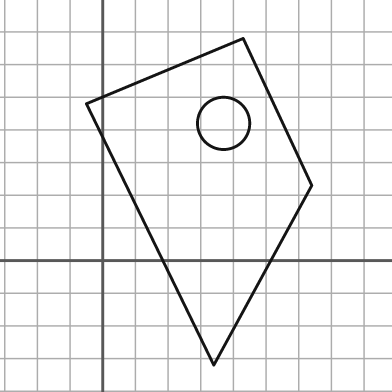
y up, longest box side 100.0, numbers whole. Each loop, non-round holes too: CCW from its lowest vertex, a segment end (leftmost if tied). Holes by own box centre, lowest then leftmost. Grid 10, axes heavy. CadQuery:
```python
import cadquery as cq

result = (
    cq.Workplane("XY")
    .moveTo(34.0, -32.0)
    .lineTo(64.0, 23.0)
    .lineTo(43.0, 68.0)
    .lineTo(-5.0, 48.0)
    .close()
    .moveTo(37.0, 42.0)
    .circle(8.0)
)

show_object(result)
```